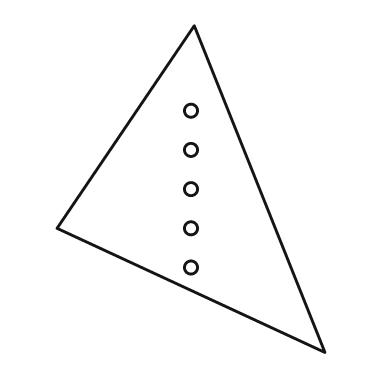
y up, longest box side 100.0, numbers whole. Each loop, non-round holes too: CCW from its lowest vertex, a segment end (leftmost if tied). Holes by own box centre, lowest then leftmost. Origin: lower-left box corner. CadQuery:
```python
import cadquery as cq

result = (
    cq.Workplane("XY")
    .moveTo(82.0, 0.0)
    .lineTo(42.0, 100.0)
    .lineTo(0.0, 38.0)
    .close()
    .moveTo(41.0, 26.0)
    .circle(2.0)
    .moveTo(41.0, 38.0)
    .circle(2.0)
    .moveTo(41.0, 50.0)
    .circle(2.0)
    .moveTo(41.0, 62.0)
    .circle(2.0)
    .moveTo(41.0, 74.0)
    .circle(2.0)
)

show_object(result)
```